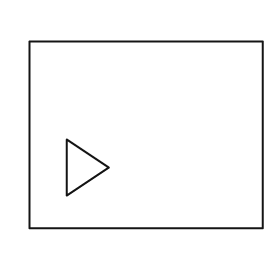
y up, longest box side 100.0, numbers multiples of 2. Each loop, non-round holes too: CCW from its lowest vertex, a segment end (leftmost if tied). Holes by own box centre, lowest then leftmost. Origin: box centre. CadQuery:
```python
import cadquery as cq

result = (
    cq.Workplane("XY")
    .moveTo(-50.0, -40.0)
    .lineTo(50.0, -40.0)
    .lineTo(50.0, 40.0)
    .lineTo(-50.0, 40.0)
    .close()
    .moveTo(-34.0, -26.0)
    .lineTo(-16.0, -14.0)
    .lineTo(-34.0, -2.0)
    .close()
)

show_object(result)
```